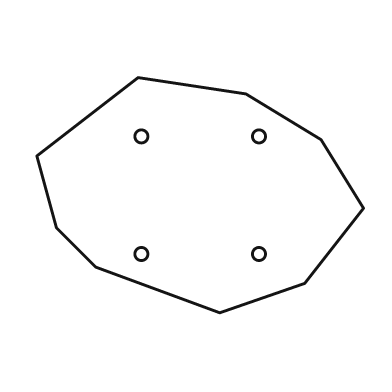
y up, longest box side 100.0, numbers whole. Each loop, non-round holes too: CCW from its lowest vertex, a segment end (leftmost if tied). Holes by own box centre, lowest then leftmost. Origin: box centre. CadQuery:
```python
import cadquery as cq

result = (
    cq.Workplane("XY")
    .moveTo(6.0, -36.0)
    .lineTo(32.0, -27.0)
    .lineTo(50.0, -4.0)
    .lineTo(37.0, 17.0)
    .lineTo(14.0, 31.0)
    .lineTo(-19.0, 36.0)
    .lineTo(-50.0, 12.0)
    .lineTo(-44.0, -10.0)
    .lineTo(-32.0, -22.0)
    .close()
    .moveTo(-18.0, -18.0)
    .circle(2.0)
    .moveTo(18.0, -18.0)
    .circle(2.0)
    .moveTo(-18.0, 18.0)
    .circle(2.0)
    .moveTo(18.0, 18.0)
    .circle(2.0)
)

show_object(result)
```